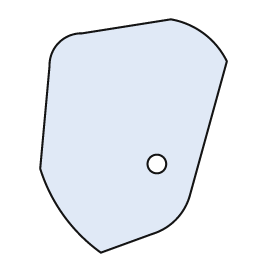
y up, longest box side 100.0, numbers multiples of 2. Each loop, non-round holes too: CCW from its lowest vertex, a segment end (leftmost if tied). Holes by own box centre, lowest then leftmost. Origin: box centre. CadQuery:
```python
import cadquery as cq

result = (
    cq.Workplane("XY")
    .moveTo(-14.0, -50.0)
    .lineTo(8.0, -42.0)
    .threePointArc((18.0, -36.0), (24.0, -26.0))
    .lineTo(40.0, 32.0)
    .threePointArc((30.0, 44.0), (16.0, 50.0))
    .lineTo(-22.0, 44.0)
    .threePointArc((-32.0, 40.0), (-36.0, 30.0))
    .lineTo(-40.0, -14.0)
    .threePointArc((-30.0, -34.0), (-14.0, -50.0))
    .close()
    .moveTo(10.0, -12.0)
    .circle(4.0)
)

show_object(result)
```